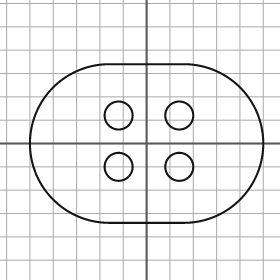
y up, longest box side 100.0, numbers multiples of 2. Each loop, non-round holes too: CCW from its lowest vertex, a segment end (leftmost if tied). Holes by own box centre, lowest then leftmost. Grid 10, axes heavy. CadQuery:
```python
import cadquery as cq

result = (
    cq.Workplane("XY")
    .moveTo(-16.0, -34.0)
    .lineTo(16.0, -34.0)
    .threePointArc((50.0, 0.0), (16.0, 34.0))
    .lineTo(-16.0, 34.0)
    .threePointArc((-50.0, 0.0), (-16.0, -34.0))
    .close()
    .moveTo(-12.0, -10.0)
    .circle(6.0)
    .moveTo(14.0, -10.0)
    .circle(6.0)
    .moveTo(-12.0, 12.0)
    .circle(6.0)
    .moveTo(14.0, 12.0)
    .circle(6.0)
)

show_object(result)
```